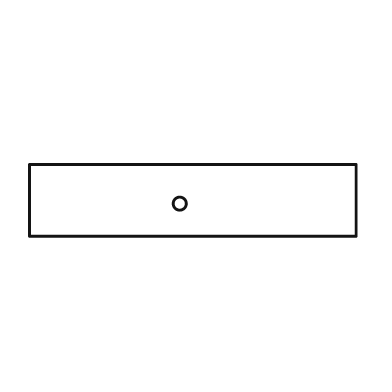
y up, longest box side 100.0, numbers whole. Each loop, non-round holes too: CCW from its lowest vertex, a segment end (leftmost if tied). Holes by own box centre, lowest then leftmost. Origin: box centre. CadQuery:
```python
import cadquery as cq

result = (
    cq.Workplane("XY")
    .moveTo(-50.0, -11.0)
    .lineTo(50.0, -11.0)
    .lineTo(50.0, 11.0)
    .lineTo(-50.0, 11.0)
    .close()
    .moveTo(-4.0, -1.0)
    .circle(2.0)
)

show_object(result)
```